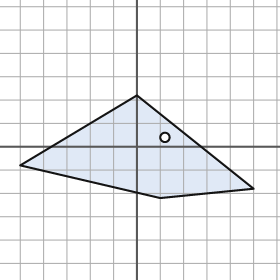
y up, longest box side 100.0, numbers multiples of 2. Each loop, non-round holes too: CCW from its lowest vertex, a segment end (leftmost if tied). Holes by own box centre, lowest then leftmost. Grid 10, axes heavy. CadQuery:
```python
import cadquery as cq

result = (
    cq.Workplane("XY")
    .moveTo(10.0, -22.0)
    .lineTo(50.0, -18.0)
    .lineTo(0.0, 22.0)
    .lineTo(-50.0, -8.0)
    .close()
    .moveTo(12.0, 4.0)
    .circle(2.0)
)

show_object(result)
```